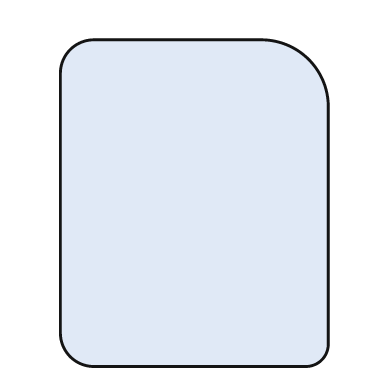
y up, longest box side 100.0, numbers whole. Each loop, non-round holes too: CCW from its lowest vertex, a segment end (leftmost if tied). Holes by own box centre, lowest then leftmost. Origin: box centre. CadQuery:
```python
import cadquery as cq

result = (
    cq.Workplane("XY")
    .moveTo(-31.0, -50.0)
    .lineTo(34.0, -50.0)
    .threePointArc((39.0, -48.0), (41.0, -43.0))
    .lineTo(41.0, 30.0)
    .threePointArc((35.0, 44.0), (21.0, 50.0))
    .lineTo(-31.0, 50.0)
    .threePointArc((-38.0, 47.0), (-41.0, 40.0))
    .lineTo(-41.0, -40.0)
    .threePointArc((-38.0, -47.0), (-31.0, -50.0))
    .close()
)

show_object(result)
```